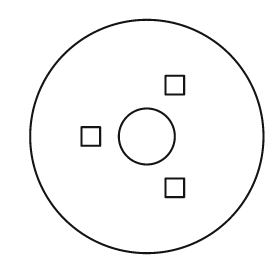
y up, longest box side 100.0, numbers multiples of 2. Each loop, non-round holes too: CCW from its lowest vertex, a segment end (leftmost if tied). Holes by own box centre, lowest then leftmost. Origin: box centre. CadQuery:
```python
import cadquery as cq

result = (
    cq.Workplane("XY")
    .moveTo(0.0, 0.0)
    .circle(50.0)
    .moveTo(8.0, -26.0)
    .lineTo(16.0, -26.0)
    .lineTo(16.0, -18.0)
    .lineTo(8.0, -18.0)
    .close()
    .moveTo(-28.0, -4.0)
    .lineTo(-20.0, -4.0)
    .lineTo(-20.0, 4.0)
    .lineTo(-28.0, 4.0)
    .close()
    .moveTo(0.0, 0.0)
    .circle(12.0)
    .moveTo(8.0, 18.0)
    .lineTo(16.0, 18.0)
    .lineTo(16.0, 26.0)
    .lineTo(8.0, 26.0)
    .close()
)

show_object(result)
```